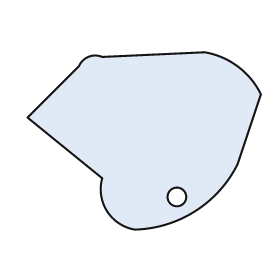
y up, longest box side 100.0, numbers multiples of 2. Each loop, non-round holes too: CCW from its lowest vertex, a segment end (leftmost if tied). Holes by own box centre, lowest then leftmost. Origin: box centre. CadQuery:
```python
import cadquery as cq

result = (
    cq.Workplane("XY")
    .moveTo(-4.0, -38.0)
    .threePointArc((22.0, -30.0), (40.0, -10.0))
    .lineTo(50.0, 20.0)
    .threePointArc((40.0, 32.0), (26.0, 38.0))
    .lineTo(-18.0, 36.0)
    .threePointArc((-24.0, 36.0), (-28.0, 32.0))
    .lineTo(-50.0, 10.0)
    .lineTo(-18.0, -16.0)
    .threePointArc((-16.0, -30.0), (-4.0, -38.0))
    .close()
    .moveTo(14.0, -24.0)
    .circle(4.0)
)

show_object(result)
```